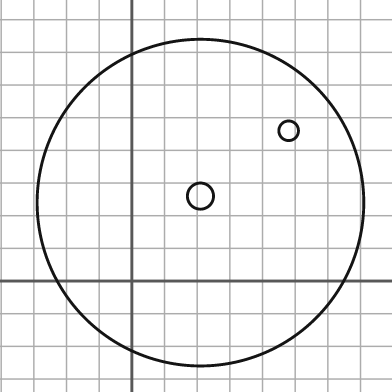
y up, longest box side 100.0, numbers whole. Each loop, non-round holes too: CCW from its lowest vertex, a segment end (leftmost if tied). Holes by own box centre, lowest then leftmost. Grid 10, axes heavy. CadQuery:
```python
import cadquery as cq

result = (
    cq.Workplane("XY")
    .moveTo(21.0, 24.0)
    .circle(50.0)
    .moveTo(21.0, 26.0)
    .circle(4.0)
    .moveTo(48.0, 46.0)
    .circle(3.0)
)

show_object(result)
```